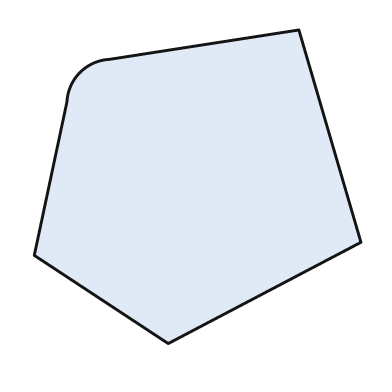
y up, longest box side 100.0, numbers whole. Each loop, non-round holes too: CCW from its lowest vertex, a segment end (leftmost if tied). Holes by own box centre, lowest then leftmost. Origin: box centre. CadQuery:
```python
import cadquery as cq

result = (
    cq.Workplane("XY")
    .moveTo(-9.0, -48.0)
    .lineTo(50.0, -17.0)
    .lineTo(31.0, 48.0)
    .lineTo(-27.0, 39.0)
    .threePointArc((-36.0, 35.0), (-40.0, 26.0))
    .lineTo(-50.0, -21.0)
    .close()
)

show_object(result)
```